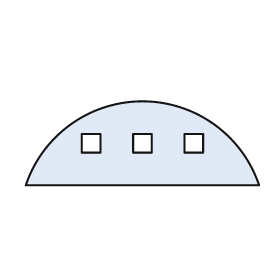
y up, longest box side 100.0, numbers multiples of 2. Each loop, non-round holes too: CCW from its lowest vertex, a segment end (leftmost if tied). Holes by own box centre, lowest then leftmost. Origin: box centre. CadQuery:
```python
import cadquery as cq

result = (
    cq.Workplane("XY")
    .moveTo(-50.0, -18.0)
    .lineTo(50.0, -18.0)
    .threePointArc((0.0, 18.0), (-50.0, -18.0))
    .close()
    .moveTo(-26.0, -4.0)
    .lineTo(-18.0, -4.0)
    .lineTo(-18.0, 4.0)
    .lineTo(-26.0, 4.0)
    .close()
    .moveTo(-4.0, -4.0)
    .lineTo(4.0, -4.0)
    .lineTo(4.0, 4.0)
    .lineTo(-4.0, 4.0)
    .close()
    .moveTo(18.0, -4.0)
    .lineTo(26.0, -4.0)
    .lineTo(26.0, 4.0)
    .lineTo(18.0, 4.0)
    .close()
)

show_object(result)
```